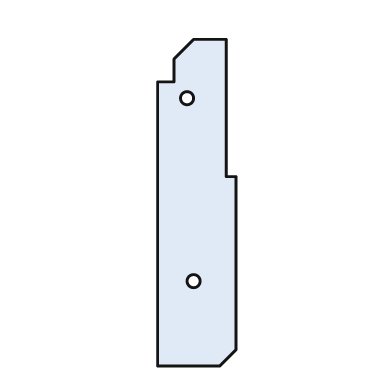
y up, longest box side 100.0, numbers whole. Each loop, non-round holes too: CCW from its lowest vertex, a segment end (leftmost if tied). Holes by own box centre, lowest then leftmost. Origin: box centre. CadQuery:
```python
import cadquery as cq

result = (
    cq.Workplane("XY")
    .moveTo(-12.0, -50.0)
    .lineTo(7.0, -50.0)
    .lineTo(12.0, -45.0)
    .lineTo(12.0, 8.0)
    .lineTo(9.0, 8.0)
    .lineTo(9.0, 50.0)
    .lineTo(-1.0, 50.0)
    .lineTo(-7.0, 44.0)
    .lineTo(-7.0, 37.0)
    .lineTo(-12.0, 37.0)
    .close()
    .moveTo(-1.0, -24.0)
    .circle(2.0)
    .moveTo(-3.0, 32.0)
    .circle(2.0)
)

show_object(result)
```